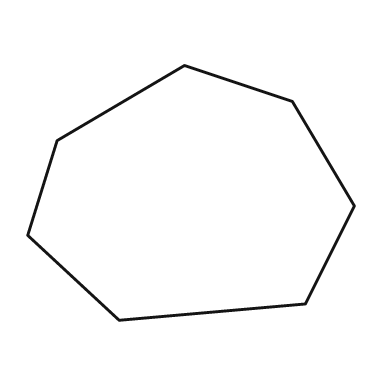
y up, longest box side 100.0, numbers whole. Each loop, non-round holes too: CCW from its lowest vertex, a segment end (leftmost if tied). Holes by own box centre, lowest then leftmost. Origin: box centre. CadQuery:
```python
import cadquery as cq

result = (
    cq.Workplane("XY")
    .moveTo(-22.0, -39.0)
    .lineTo(35.0, -34.0)
    .lineTo(50.0, -4.0)
    .lineTo(31.0, 28.0)
    .lineTo(-2.0, 39.0)
    .lineTo(-41.0, 16.0)
    .lineTo(-50.0, -13.0)
    .close()
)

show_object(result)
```